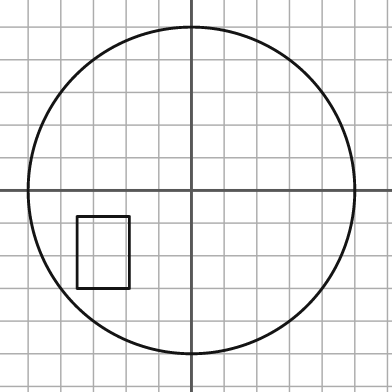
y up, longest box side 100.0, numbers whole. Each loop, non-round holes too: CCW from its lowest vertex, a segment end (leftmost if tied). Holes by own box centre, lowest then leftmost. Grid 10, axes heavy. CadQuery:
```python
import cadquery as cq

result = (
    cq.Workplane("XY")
    .moveTo(0.0, 0.0)
    .circle(50.0)
    .moveTo(-35.0, -30.0)
    .lineTo(-19.0, -30.0)
    .lineTo(-19.0, -8.0)
    .lineTo(-35.0, -8.0)
    .close()
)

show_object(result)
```